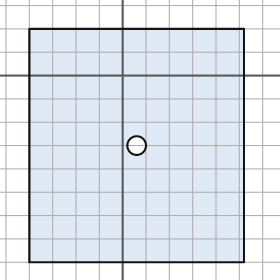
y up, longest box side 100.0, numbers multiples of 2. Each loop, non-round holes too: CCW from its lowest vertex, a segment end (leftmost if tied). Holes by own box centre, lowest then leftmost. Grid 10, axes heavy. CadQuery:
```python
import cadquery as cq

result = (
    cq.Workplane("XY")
    .moveTo(-40.0, -80.0)
    .lineTo(52.0, -80.0)
    .lineTo(52.0, 20.0)
    .lineTo(-40.0, 20.0)
    .close()
    .moveTo(6.0, -30.0)
    .circle(4.0)
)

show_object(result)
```